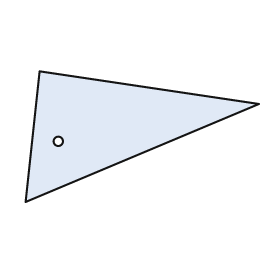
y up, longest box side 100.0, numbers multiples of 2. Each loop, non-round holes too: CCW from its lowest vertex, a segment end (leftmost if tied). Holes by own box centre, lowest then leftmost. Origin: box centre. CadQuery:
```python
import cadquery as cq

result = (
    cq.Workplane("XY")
    .moveTo(-50.0, -28.0)
    .lineTo(50.0, 14.0)
    .lineTo(-44.0, 28.0)
    .close()
    .moveTo(-36.0, -2.0)
    .circle(2.0)
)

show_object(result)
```